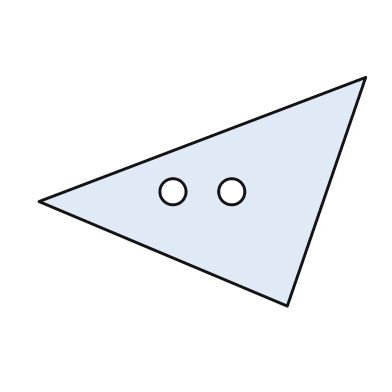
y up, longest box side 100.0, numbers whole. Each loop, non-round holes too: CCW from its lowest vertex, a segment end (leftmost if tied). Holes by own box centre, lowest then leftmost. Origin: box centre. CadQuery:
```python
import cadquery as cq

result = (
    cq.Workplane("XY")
    .moveTo(26.0, -35.0)
    .lineTo(50.0, 35.0)
    .lineTo(-50.0, -3.0)
    .close()
    .moveTo(-9.0, 0.0)
    .circle(4.0)
    .moveTo(9.0, 0.0)
    .circle(4.0)
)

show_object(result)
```